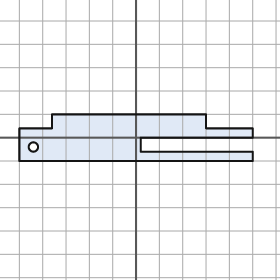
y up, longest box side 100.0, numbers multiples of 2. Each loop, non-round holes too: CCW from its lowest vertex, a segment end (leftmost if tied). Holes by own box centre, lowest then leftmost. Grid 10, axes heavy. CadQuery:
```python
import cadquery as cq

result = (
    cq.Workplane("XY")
    .moveTo(-50.0, -10.0)
    .lineTo(50.0, -10.0)
    .lineTo(50.0, -6.0)
    .lineTo(2.0, -6.0)
    .lineTo(2.0, 0.0)
    .lineTo(50.0, 0.0)
    .lineTo(50.0, 4.0)
    .lineTo(30.0, 4.0)
    .lineTo(30.0, 10.0)
    .lineTo(-36.0, 10.0)
    .lineTo(-36.0, 4.0)
    .lineTo(-50.0, 4.0)
    .close()
    .moveTo(-44.0, -4.0)
    .circle(2.0)
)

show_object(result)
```